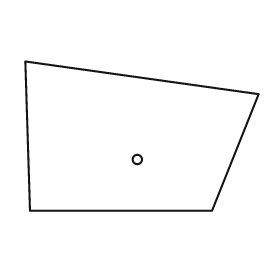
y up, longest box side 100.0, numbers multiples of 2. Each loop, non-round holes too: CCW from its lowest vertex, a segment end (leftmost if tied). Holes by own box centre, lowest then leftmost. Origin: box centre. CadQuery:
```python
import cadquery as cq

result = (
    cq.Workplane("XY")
    .moveTo(-48.0, -32.0)
    .lineTo(30.0, -32.0)
    .lineTo(50.0, 18.0)
    .lineTo(-50.0, 32.0)
    .close()
    .moveTo(-2.0, -10.0)
    .circle(2.0)
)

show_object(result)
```